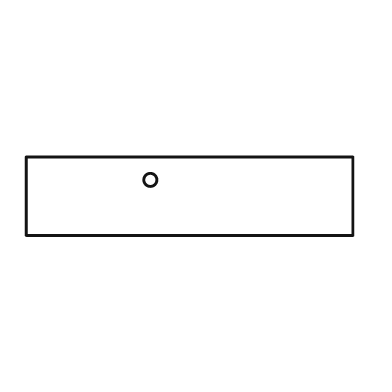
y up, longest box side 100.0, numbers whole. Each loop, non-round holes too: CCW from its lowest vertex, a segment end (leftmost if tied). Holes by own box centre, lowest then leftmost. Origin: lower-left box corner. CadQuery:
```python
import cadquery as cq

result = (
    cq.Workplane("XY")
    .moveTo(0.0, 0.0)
    .lineTo(100.0, 0.0)
    .lineTo(100.0, 24.0)
    .lineTo(0.0, 24.0)
    .close()
    .moveTo(38.0, 17.0)
    .circle(2.0)
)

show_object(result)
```